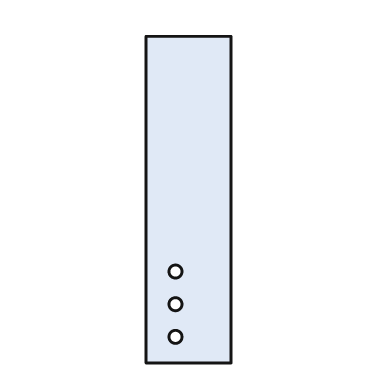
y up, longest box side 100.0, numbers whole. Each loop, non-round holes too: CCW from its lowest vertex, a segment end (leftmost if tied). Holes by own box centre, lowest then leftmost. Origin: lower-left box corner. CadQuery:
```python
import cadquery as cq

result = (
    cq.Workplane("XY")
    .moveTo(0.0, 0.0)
    .lineTo(26.0, 0.0)
    .lineTo(26.0, 100.0)
    .lineTo(0.0, 100.0)
    .close()
    .moveTo(9.0, 8.0)
    .circle(2.0)
    .moveTo(9.0, 18.0)
    .circle(2.0)
    .moveTo(9.0, 28.0)
    .circle(2.0)
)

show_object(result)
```